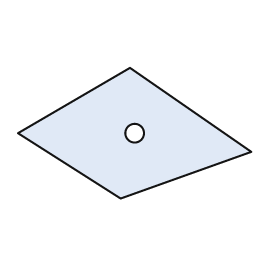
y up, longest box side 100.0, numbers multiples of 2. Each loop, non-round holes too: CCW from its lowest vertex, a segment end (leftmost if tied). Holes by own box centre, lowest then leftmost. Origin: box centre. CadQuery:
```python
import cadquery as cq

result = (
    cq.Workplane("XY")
    .moveTo(-6.0, -28.0)
    .lineTo(50.0, -8.0)
    .lineTo(-2.0, 28.0)
    .lineTo(-50.0, 0.0)
    .close()
    .moveTo(0.0, 0.0)
    .circle(4.0)
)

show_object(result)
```